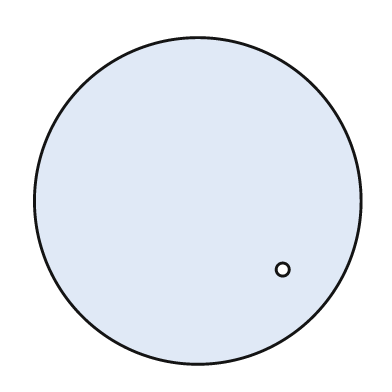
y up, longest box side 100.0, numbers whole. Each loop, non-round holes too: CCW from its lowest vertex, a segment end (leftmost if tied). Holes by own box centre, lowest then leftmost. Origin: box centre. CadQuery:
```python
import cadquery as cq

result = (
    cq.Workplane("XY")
    .moveTo(0.0, 0.0)
    .circle(50.0)
    .moveTo(26.0, -21.0)
    .circle(2.0)
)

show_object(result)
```